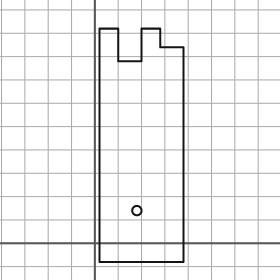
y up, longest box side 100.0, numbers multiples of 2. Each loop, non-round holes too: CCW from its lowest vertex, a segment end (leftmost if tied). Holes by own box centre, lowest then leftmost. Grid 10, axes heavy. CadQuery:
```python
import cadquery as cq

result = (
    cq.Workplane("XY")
    .moveTo(2.0, -8.0)
    .lineTo(38.0, -8.0)
    .lineTo(38.0, 84.0)
    .lineTo(28.0, 84.0)
    .lineTo(28.0, 92.0)
    .lineTo(20.0, 92.0)
    .lineTo(20.0, 78.0)
    .lineTo(10.0, 78.0)
    .lineTo(10.0, 92.0)
    .lineTo(2.0, 92.0)
    .close()
    .moveTo(18.0, 14.0)
    .circle(2.0)
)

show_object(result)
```